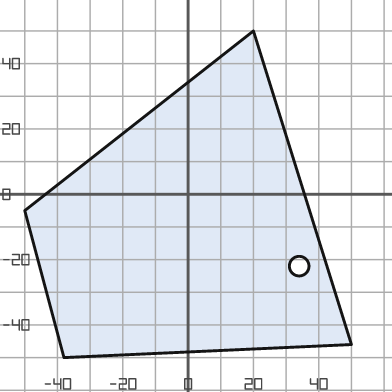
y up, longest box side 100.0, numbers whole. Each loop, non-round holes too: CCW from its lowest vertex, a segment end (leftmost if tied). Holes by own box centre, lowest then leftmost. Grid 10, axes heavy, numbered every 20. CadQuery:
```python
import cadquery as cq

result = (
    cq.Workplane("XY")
    .moveTo(-38.0, -50.0)
    .lineTo(50.0, -46.0)
    .lineTo(20.0, 50.0)
    .lineTo(-50.0, -5.0)
    .close()
    .moveTo(34.0, -22.0)
    .circle(3.0)
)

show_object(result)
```